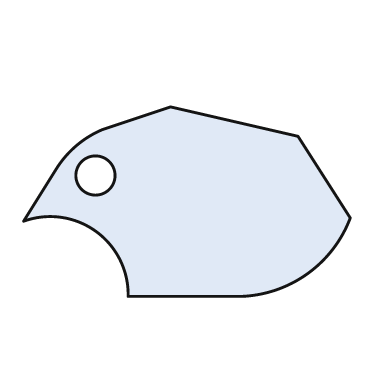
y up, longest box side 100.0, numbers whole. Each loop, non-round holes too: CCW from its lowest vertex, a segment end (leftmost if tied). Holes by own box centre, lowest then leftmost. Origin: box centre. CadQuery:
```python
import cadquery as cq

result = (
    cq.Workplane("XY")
    .moveTo(-18.0, -29.0)
    .lineTo(17.0, -29.0)
    .threePointArc((37.0, -22.0), (50.0, -5.0))
    .lineTo(34.0, 20.0)
    .lineTo(-5.0, 29.0)
    .lineTo(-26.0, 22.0)
    .threePointArc((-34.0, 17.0), (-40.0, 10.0))
    .lineTo(-50.0, -6.0)
    .threePointArc((-28.0, -9.0), (-18.0, -29.0))
    .close()
    .moveTo(-28.0, 8.0)
    .circle(6.0)
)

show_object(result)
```